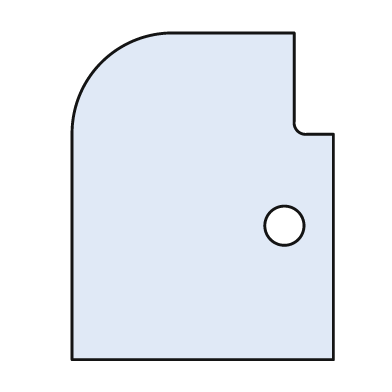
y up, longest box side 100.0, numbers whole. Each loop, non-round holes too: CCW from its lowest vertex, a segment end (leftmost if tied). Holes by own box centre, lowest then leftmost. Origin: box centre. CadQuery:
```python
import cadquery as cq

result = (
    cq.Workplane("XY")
    .moveTo(-40.0, -50.0)
    .lineTo(40.0, -50.0)
    .lineTo(40.0, 19.0)
    .lineTo(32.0, 19.0)
    .threePointArc((29.0, 20.0), (28.0, 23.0))
    .lineTo(28.0, 50.0)
    .lineTo(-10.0, 50.0)
    .threePointArc((-31.0, 41.0), (-40.0, 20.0))
    .close()
    .moveTo(25.0, -9.0)
    .circle(6.0)
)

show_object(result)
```